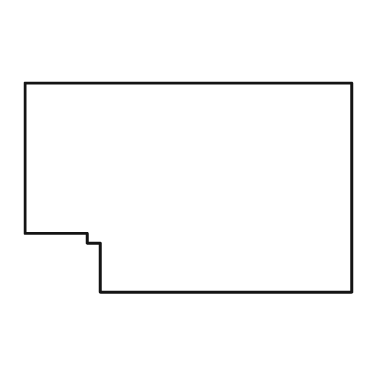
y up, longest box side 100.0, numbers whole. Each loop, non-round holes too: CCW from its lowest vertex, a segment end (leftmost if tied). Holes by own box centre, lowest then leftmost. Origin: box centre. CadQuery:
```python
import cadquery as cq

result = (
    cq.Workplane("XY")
    .moveTo(-27.0, -32.0)
    .lineTo(50.0, -32.0)
    .lineTo(50.0, 32.0)
    .lineTo(-50.0, 32.0)
    .lineTo(-50.0, -14.0)
    .lineTo(-31.0, -14.0)
    .lineTo(-31.0, -17.0)
    .lineTo(-27.0, -17.0)
    .close()
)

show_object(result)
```